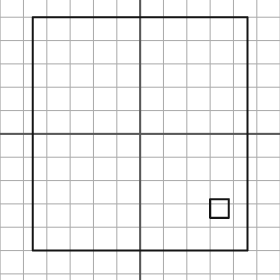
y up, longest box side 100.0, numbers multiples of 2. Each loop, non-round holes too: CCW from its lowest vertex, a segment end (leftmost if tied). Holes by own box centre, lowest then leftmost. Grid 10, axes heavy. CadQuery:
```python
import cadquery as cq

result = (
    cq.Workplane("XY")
    .moveTo(-46.0, -50.0)
    .lineTo(46.0, -50.0)
    .lineTo(46.0, 50.0)
    .lineTo(-46.0, 50.0)
    .close()
    .moveTo(30.0, -36.0)
    .lineTo(38.0, -36.0)
    .lineTo(38.0, -28.0)
    .lineTo(30.0, -28.0)
    .close()
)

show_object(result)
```